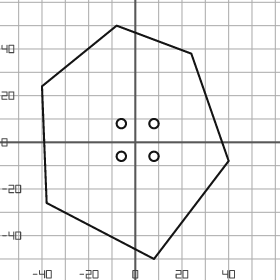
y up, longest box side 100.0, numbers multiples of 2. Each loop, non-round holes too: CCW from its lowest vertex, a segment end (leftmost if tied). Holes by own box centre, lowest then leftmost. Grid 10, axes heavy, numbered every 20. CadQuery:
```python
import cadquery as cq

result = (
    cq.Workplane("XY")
    .moveTo(8.0, -50.0)
    .lineTo(40.0, -8.0)
    .lineTo(24.0, 38.0)
    .lineTo(-8.0, 50.0)
    .lineTo(-40.0, 24.0)
    .lineTo(-38.0, -26.0)
    .close()
    .moveTo(-6.0, -6.0)
    .circle(2.0)
    .moveTo(8.0, -6.0)
    .circle(2.0)
    .moveTo(-6.0, 8.0)
    .circle(2.0)
    .moveTo(8.0, 8.0)
    .circle(2.0)
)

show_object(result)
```